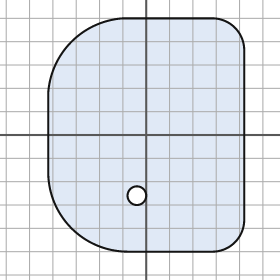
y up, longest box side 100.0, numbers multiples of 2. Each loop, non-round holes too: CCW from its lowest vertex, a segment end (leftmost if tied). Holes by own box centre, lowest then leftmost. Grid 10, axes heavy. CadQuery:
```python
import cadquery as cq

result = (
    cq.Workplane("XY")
    .moveTo(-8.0, -50.0)
    .lineTo(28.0, -50.0)
    .threePointArc((38.0, -46.0), (42.0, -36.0))
    .lineTo(42.0, 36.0)
    .threePointArc((38.0, 46.0), (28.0, 50.0))
    .lineTo(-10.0, 50.0)
    .threePointArc((-32.0, 40.0), (-42.0, 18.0))
    .lineTo(-42.0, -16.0)
    .threePointArc((-32.0, -40.0), (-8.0, -50.0))
    .close()
    .moveTo(-4.0, -26.0)
    .circle(4.0)
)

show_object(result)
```